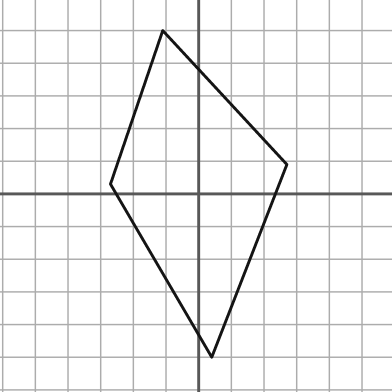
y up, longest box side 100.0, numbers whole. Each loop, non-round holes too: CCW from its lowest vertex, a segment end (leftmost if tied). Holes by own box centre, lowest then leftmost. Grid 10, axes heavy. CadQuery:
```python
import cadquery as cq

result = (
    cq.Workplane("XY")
    .moveTo(4.0, -50.0)
    .lineTo(27.0, 9.0)
    .lineTo(-11.0, 50.0)
    .lineTo(-27.0, 3.0)
    .close()
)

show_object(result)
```